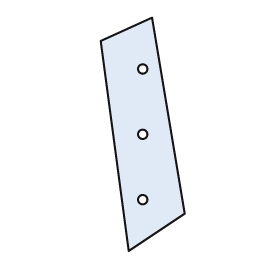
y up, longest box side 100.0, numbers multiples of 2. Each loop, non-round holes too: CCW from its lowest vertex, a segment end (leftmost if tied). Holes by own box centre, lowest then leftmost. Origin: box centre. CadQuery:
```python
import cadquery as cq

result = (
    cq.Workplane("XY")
    .moveTo(-6.0, -50.0)
    .lineTo(18.0, -34.0)
    .lineTo(4.0, 50.0)
    .lineTo(-18.0, 40.0)
    .close()
    .moveTo(0.0, -28.0)
    .circle(2.0)
    .moveTo(0.0, 0.0)
    .circle(2.0)
    .moveTo(0.0, 28.0)
    .circle(2.0)
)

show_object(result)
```